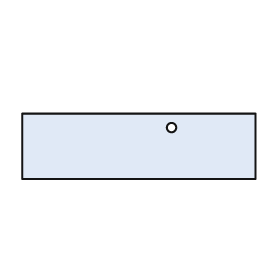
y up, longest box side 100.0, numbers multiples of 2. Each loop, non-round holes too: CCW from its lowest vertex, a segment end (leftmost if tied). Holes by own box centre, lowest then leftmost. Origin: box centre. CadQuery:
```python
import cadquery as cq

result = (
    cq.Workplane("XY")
    .moveTo(-50.0, -14.0)
    .lineTo(50.0, -14.0)
    .lineTo(50.0, 14.0)
    .lineTo(-50.0, 14.0)
    .close()
    .moveTo(14.0, 8.0)
    .circle(2.0)
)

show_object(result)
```